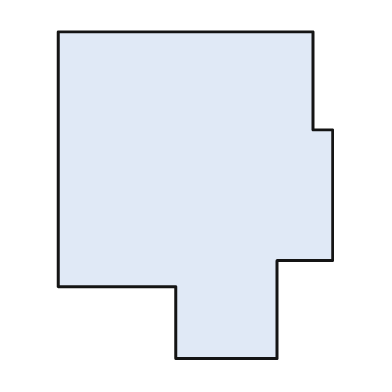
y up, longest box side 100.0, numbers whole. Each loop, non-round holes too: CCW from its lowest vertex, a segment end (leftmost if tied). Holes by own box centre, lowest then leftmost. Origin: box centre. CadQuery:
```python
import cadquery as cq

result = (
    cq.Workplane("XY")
    .moveTo(-6.0, -50.0)
    .lineTo(25.0, -50.0)
    .lineTo(25.0, -20.0)
    .lineTo(42.0, -20.0)
    .lineTo(42.0, 20.0)
    .lineTo(36.0, 20.0)
    .lineTo(36.0, 50.0)
    .lineTo(-42.0, 50.0)
    .lineTo(-42.0, -28.0)
    .lineTo(-6.0, -28.0)
    .close()
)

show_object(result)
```